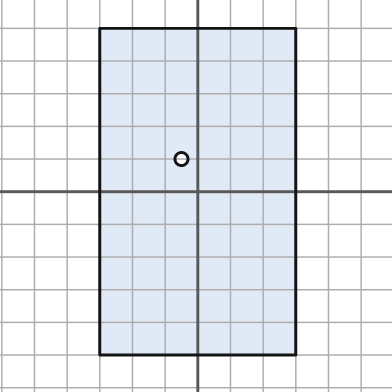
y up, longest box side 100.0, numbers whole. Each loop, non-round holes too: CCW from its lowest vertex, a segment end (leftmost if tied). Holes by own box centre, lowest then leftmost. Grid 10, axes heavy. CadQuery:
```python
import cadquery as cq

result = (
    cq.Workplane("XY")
    .moveTo(-30.0, -50.0)
    .lineTo(30.0, -50.0)
    .lineTo(30.0, 50.0)
    .lineTo(-30.0, 50.0)
    .close()
    .moveTo(-5.0, 10.0)
    .circle(2.0)
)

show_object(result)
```